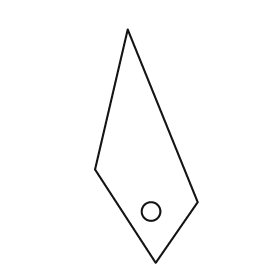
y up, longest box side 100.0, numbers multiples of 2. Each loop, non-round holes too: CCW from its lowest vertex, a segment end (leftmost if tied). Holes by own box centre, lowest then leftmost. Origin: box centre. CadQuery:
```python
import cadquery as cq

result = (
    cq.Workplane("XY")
    .moveTo(4.0, -50.0)
    .lineTo(22.0, -24.0)
    .lineTo(-8.0, 50.0)
    .lineTo(-22.0, -10.0)
    .close()
    .moveTo(2.0, -28.0)
    .circle(4.0)
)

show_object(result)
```